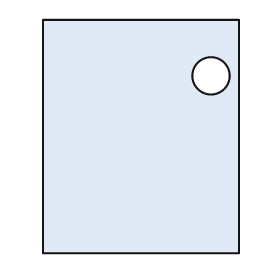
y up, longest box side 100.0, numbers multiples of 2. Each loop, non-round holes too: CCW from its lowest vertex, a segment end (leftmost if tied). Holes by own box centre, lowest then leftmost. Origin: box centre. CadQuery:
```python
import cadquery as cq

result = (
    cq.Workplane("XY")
    .moveTo(-42.0, -50.0)
    .lineTo(42.0, -50.0)
    .lineTo(42.0, 50.0)
    .lineTo(-42.0, 50.0)
    .close()
    .moveTo(30.0, 26.0)
    .circle(8.0)
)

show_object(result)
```